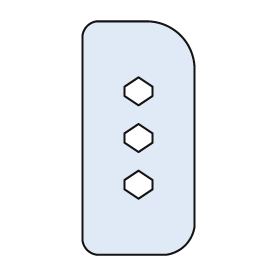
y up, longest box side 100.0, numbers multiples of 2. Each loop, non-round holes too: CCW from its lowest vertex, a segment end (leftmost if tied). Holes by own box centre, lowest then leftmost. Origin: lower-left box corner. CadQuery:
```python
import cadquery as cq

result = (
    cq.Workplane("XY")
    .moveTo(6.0, 0.0)
    .lineTo(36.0, 0.0)
    .threePointArc((44.0, 4.0), (48.0, 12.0))
    .lineTo(48.0, 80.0)
    .threePointArc((42.0, 94.0), (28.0, 100.0))
    .lineTo(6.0, 100.0)
    .threePointArc((2.0, 98.0), (0.0, 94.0))
    .lineTo(0.0, 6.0)
    .threePointArc((2.0, 2.0), (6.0, 0.0))
    .close()
    .moveTo(24.0, 24.0)
    .lineTo(30.0, 28.0)
    .lineTo(30.0, 32.0)
    .lineTo(24.0, 36.0)
    .lineTo(18.0, 32.0)
    .lineTo(18.0, 28.0)
    .close()
    .moveTo(24.0, 44.0)
    .lineTo(30.0, 48.0)
    .lineTo(30.0, 52.0)
    .lineTo(24.0, 56.0)
    .lineTo(18.0, 52.0)
    .lineTo(18.0, 48.0)
    .close()
    .moveTo(24.0, 64.0)
    .lineTo(30.0, 68.0)
    .lineTo(30.0, 72.0)
    .lineTo(24.0, 76.0)
    .lineTo(18.0, 72.0)
    .lineTo(18.0, 68.0)
    .close()
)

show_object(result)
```